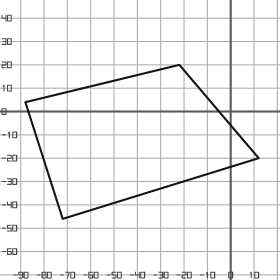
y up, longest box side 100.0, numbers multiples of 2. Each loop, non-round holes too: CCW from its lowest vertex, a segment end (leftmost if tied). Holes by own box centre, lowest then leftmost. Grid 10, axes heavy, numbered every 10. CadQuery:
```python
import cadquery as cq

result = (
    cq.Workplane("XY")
    .moveTo(-72.0, -46.0)
    .lineTo(12.0, -20.0)
    .lineTo(-22.0, 20.0)
    .lineTo(-88.0, 4.0)
    .close()
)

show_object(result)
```